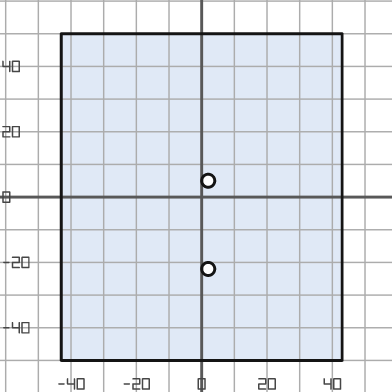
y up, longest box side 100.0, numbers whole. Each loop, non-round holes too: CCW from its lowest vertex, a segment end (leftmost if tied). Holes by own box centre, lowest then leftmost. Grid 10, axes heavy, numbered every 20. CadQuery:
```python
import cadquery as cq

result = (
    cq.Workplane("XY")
    .moveTo(-43.0, -50.0)
    .lineTo(43.0, -50.0)
    .lineTo(43.0, 50.0)
    .lineTo(-43.0, 50.0)
    .close()
    .moveTo(2.0, -22.0)
    .circle(2.0)
    .moveTo(2.0, 5.0)
    .circle(2.0)
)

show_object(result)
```